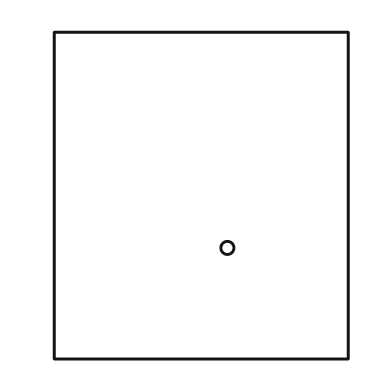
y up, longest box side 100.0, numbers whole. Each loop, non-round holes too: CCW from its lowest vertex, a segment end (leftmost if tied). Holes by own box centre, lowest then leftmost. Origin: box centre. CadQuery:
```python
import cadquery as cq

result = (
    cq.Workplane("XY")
    .moveTo(-45.0, -50.0)
    .lineTo(45.0, -50.0)
    .lineTo(45.0, 50.0)
    .lineTo(-45.0, 50.0)
    .close()
    .moveTo(8.0, -16.0)
    .circle(2.0)
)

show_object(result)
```